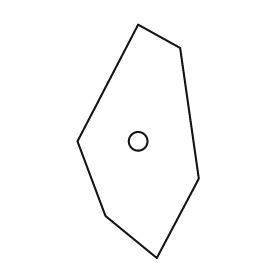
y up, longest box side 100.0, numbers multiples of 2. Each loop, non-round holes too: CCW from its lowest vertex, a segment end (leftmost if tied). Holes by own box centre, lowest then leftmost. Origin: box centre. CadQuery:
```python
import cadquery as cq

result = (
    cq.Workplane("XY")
    .moveTo(8.0, -50.0)
    .lineTo(26.0, -16.0)
    .lineTo(18.0, 40.0)
    .lineTo(0.0, 50.0)
    .lineTo(-26.0, 0.0)
    .lineTo(-14.0, -32.0)
    .close()
    .moveTo(0.0, 0.0)
    .circle(4.0)
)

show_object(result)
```